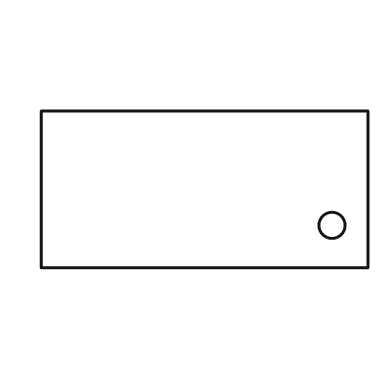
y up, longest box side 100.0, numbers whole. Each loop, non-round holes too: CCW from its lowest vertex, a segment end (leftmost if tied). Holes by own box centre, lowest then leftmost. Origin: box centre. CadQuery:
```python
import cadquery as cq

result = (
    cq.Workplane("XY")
    .moveTo(-50.0, -24.0)
    .lineTo(50.0, -24.0)
    .lineTo(50.0, 24.0)
    .lineTo(-50.0, 24.0)
    .close()
    .moveTo(39.0, -11.0)
    .circle(4.0)
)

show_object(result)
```